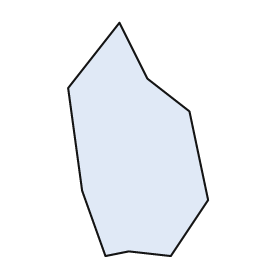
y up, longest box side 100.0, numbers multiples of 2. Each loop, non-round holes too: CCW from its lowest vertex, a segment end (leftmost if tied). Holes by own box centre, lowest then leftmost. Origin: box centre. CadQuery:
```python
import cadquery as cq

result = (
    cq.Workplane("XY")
    .moveTo(-14.0, -50.0)
    .lineTo(-4.0, -48.0)
    .lineTo(14.0, -50.0)
    .lineTo(30.0, -26.0)
    .lineTo(22.0, 12.0)
    .lineTo(4.0, 26.0)
    .lineTo(-8.0, 50.0)
    .lineTo(-30.0, 22.0)
    .lineTo(-24.0, -22.0)
    .close()
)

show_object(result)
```